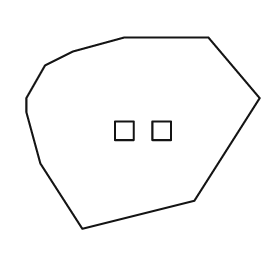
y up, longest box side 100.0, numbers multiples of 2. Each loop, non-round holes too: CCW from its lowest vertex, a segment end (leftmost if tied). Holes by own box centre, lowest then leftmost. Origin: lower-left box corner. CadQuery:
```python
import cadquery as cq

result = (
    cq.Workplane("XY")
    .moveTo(24.0, 0.0)
    .lineTo(72.0, 12.0)
    .lineTo(100.0, 56.0)
    .lineTo(78.0, 82.0)
    .lineTo(42.0, 82.0)
    .lineTo(20.0, 76.0)
    .lineTo(8.0, 70.0)
    .lineTo(0.0, 56.0)
    .lineTo(0.0, 50.0)
    .lineTo(6.0, 28.0)
    .close()
    .moveTo(38.0, 38.0)
    .lineTo(46.0, 38.0)
    .lineTo(46.0, 46.0)
    .lineTo(38.0, 46.0)
    .close()
    .moveTo(54.0, 38.0)
    .lineTo(62.0, 38.0)
    .lineTo(62.0, 46.0)
    .lineTo(54.0, 46.0)
    .close()
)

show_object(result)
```